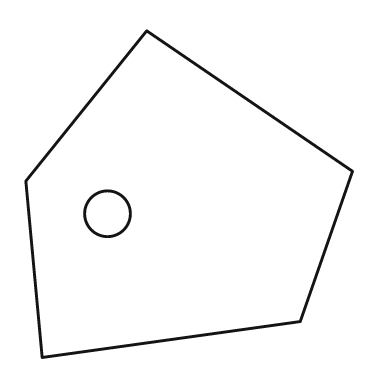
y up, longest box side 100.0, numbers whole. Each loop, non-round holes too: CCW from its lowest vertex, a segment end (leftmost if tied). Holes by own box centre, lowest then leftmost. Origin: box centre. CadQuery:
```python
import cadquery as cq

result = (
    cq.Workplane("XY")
    .moveTo(-45.0, -50.0)
    .lineTo(34.0, -39.0)
    .lineTo(50.0, 7.0)
    .lineTo(-13.0, 50.0)
    .lineTo(-50.0, 4.0)
    .close()
    .moveTo(-25.0, -6.0)
    .circle(7.0)
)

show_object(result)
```